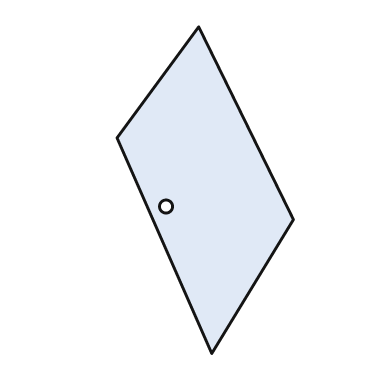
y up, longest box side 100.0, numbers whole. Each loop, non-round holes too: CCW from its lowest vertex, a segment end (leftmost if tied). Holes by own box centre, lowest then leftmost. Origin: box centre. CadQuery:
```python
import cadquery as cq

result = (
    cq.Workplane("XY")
    .moveTo(2.0, -50.0)
    .lineTo(27.0, -9.0)
    .lineTo(-2.0, 50.0)
    .lineTo(-27.0, 16.0)
    .close()
    .moveTo(-12.0, -5.0)
    .circle(2.0)
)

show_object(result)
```